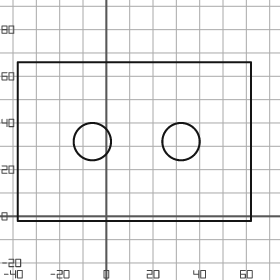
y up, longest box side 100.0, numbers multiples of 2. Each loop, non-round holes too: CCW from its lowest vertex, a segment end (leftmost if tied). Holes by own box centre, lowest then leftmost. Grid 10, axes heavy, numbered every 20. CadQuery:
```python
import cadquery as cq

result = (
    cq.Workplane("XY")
    .moveTo(-38.0, -2.0)
    .lineTo(62.0, -2.0)
    .lineTo(62.0, 66.0)
    .lineTo(-38.0, 66.0)
    .close()
    .moveTo(-6.0, 32.0)
    .circle(8.0)
    .moveTo(32.0, 32.0)
    .circle(8.0)
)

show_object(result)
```